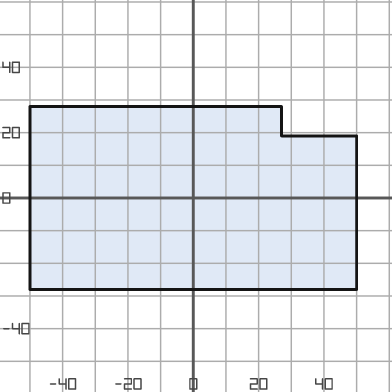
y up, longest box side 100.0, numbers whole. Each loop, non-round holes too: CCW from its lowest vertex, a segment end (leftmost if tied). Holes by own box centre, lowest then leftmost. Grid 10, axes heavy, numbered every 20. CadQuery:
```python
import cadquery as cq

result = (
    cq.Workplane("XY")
    .moveTo(-50.0, -28.0)
    .lineTo(50.0, -28.0)
    .lineTo(50.0, 19.0)
    .lineTo(27.0, 19.0)
    .lineTo(27.0, 28.0)
    .lineTo(-50.0, 28.0)
    .close()
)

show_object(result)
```